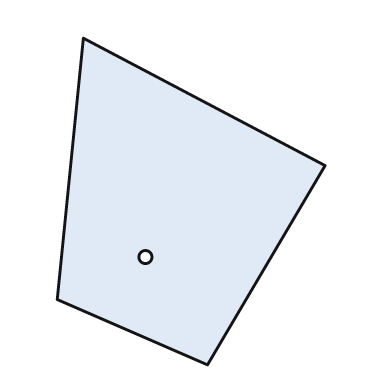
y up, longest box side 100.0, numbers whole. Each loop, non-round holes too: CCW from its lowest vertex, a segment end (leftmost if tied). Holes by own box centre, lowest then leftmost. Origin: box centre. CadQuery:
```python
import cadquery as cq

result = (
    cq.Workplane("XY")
    .moveTo(5.0, -50.0)
    .lineTo(41.0, 11.0)
    .lineTo(-33.0, 50.0)
    .lineTo(-41.0, -30.0)
    .close()
    .moveTo(-14.0, -17.0)
    .circle(2.0)
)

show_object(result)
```